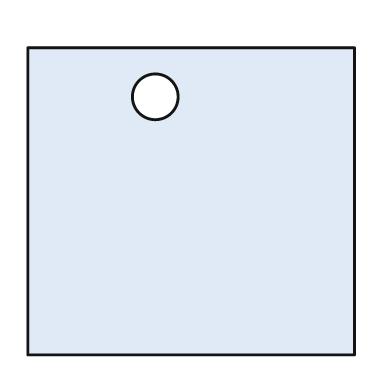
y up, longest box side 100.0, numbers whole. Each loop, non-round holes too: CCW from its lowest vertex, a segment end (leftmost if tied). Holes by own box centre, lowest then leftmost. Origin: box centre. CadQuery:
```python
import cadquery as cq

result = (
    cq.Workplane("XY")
    .moveTo(-50.0, -47.0)
    .lineTo(50.0, -47.0)
    .lineTo(50.0, 47.0)
    .lineTo(-50.0, 47.0)
    .close()
    .moveTo(-11.0, 32.0)
    .circle(7.0)
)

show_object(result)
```